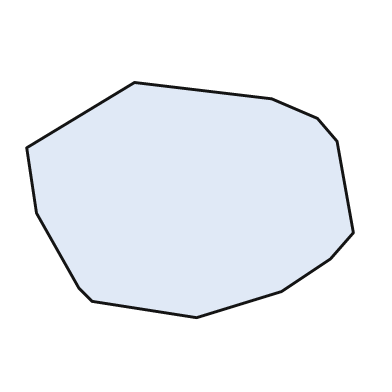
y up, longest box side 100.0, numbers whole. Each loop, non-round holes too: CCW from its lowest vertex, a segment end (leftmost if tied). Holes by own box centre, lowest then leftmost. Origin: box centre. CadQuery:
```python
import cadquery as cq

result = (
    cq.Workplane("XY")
    .moveTo(2.0, -36.0)
    .lineTo(28.0, -28.0)
    .lineTo(43.0, -18.0)
    .lineTo(50.0, -10.0)
    .lineTo(45.0, 18.0)
    .lineTo(39.0, 25.0)
    .lineTo(25.0, 31.0)
    .lineTo(-17.0, 36.0)
    .lineTo(-50.0, 16.0)
    .lineTo(-47.0, -4.0)
    .lineTo(-34.0, -27.0)
    .lineTo(-30.0, -31.0)
    .close()
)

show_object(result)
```